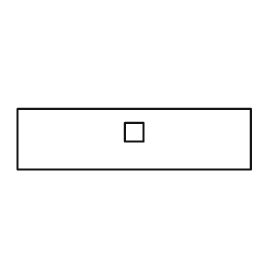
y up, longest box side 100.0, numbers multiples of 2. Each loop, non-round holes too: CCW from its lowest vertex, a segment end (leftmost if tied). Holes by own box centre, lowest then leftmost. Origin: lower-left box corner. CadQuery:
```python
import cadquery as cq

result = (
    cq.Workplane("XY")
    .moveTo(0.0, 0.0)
    .lineTo(100.0, 0.0)
    .lineTo(100.0, 26.0)
    .lineTo(0.0, 26.0)
    .close()
    .moveTo(46.0, 12.0)
    .lineTo(54.0, 12.0)
    .lineTo(54.0, 20.0)
    .lineTo(46.0, 20.0)
    .close()
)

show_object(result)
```